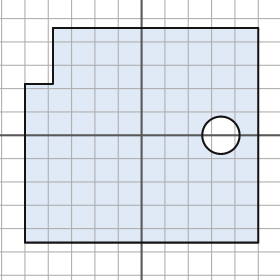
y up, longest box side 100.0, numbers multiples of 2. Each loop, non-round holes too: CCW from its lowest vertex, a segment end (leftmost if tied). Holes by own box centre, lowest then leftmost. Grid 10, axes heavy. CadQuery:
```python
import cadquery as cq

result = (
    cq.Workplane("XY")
    .moveTo(-50.0, -46.0)
    .lineTo(50.0, -46.0)
    .lineTo(50.0, 46.0)
    .lineTo(-38.0, 46.0)
    .lineTo(-38.0, 22.0)
    .lineTo(-50.0, 22.0)
    .close()
    .moveTo(34.0, 0.0)
    .circle(8.0)
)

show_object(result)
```